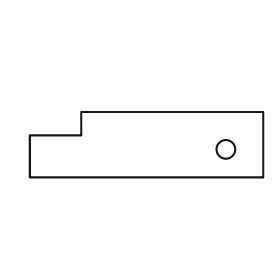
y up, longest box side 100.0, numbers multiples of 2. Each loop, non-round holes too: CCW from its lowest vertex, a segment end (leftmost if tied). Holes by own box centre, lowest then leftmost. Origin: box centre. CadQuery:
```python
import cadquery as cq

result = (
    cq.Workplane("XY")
    .moveTo(-50.0, -14.0)
    .lineTo(50.0, -14.0)
    .lineTo(50.0, 14.0)
    .lineTo(-28.0, 14.0)
    .lineTo(-28.0, 4.0)
    .lineTo(-50.0, 4.0)
    .close()
    .moveTo(34.0, -2.0)
    .circle(4.0)
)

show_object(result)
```